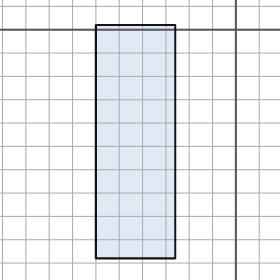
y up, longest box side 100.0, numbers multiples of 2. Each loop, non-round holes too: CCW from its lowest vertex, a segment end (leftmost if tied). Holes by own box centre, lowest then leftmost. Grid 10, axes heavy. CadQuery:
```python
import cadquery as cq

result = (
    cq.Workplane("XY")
    .moveTo(-60.0, -98.0)
    .lineTo(-26.0, -98.0)
    .lineTo(-26.0, 2.0)
    .lineTo(-60.0, 2.0)
    .close()
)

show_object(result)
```